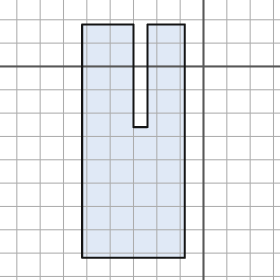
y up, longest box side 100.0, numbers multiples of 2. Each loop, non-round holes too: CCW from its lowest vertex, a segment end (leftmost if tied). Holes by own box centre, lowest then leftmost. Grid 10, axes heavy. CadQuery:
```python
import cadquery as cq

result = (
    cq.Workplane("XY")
    .moveTo(-52.0, -82.0)
    .lineTo(-8.0, -82.0)
    .lineTo(-8.0, 18.0)
    .lineTo(-24.0, 18.0)
    .lineTo(-24.0, -26.0)
    .lineTo(-30.0, -26.0)
    .lineTo(-30.0, 18.0)
    .lineTo(-52.0, 18.0)
    .close()
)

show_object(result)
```